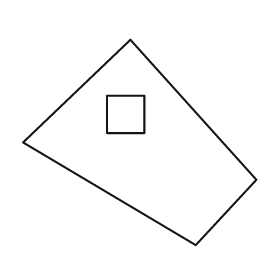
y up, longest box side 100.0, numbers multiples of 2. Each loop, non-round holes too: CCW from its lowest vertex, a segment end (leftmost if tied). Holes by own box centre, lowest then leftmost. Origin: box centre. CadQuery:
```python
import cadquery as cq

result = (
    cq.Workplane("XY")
    .moveTo(24.0, -44.0)
    .lineTo(50.0, -16.0)
    .lineTo(-4.0, 44.0)
    .lineTo(-50.0, 0.0)
    .close()
    .moveTo(-14.0, 4.0)
    .lineTo(2.0, 4.0)
    .lineTo(2.0, 20.0)
    .lineTo(-14.0, 20.0)
    .close()
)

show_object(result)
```